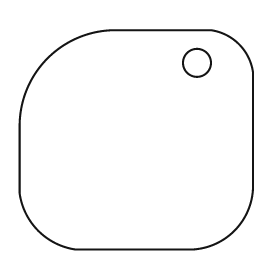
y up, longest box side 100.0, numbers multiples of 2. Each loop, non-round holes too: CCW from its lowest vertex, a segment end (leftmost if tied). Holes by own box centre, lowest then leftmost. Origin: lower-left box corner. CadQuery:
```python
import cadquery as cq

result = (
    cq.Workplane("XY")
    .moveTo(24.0, 0.0)
    .lineTo(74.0, 0.0)
    .threePointArc((92.0, 8.0), (100.0, 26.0))
    .lineTo(100.0, 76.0)
    .threePointArc((94.0, 88.0), (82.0, 94.0))
    .lineTo(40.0, 94.0)
    .threePointArc((12.0, 82.0), (0.0, 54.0))
    .lineTo(0.0, 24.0)
    .threePointArc((8.0, 8.0), (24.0, 0.0))
    .close()
    .moveTo(76.0, 80.0)
    .circle(6.0)
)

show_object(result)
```